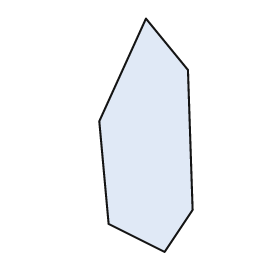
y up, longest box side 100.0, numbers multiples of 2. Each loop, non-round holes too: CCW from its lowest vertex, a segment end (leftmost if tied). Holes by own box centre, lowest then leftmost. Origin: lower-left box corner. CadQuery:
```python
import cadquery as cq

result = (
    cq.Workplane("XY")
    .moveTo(28.0, 0.0)
    .lineTo(40.0, 18.0)
    .lineTo(38.0, 78.0)
    .lineTo(20.0, 100.0)
    .lineTo(0.0, 56.0)
    .lineTo(4.0, 12.0)
    .close()
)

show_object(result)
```